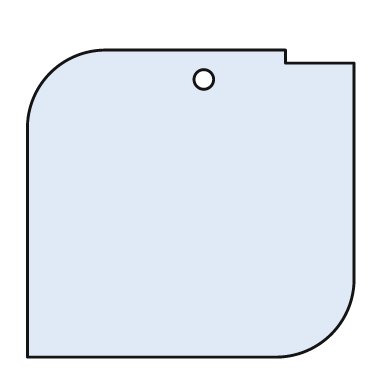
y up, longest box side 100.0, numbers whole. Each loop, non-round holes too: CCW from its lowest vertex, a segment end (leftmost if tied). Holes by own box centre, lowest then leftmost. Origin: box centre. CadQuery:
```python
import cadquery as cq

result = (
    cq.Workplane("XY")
    .moveTo(-50.0, -47.0)
    .lineTo(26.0, -47.0)
    .threePointArc((43.0, -40.0), (50.0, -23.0))
    .lineTo(50.0, 43.0)
    .lineTo(29.0, 43.0)
    .lineTo(29.0, 47.0)
    .lineTo(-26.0, 47.0)
    .threePointArc((-43.0, 40.0), (-50.0, 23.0))
    .close()
    .moveTo(4.0, 38.0)
    .circle(3.0)
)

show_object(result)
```